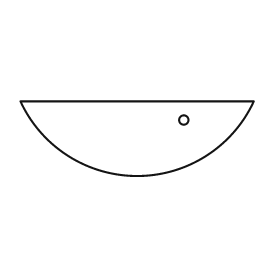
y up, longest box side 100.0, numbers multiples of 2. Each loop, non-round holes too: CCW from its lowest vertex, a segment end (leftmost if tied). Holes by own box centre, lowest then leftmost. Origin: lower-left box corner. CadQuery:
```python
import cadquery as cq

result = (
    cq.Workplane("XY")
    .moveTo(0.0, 32.0)
    .threePointArc((50.0, 0.0), (100.0, 32.0))
    .close()
    .moveTo(70.0, 24.0)
    .circle(2.0)
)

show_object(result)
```